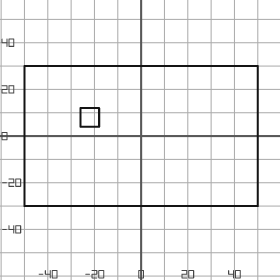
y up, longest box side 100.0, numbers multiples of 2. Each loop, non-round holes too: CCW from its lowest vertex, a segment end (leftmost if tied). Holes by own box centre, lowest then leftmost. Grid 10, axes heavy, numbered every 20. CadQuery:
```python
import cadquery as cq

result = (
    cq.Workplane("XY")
    .moveTo(-50.0, -30.0)
    .lineTo(50.0, -30.0)
    .lineTo(50.0, 30.0)
    .lineTo(-50.0, 30.0)
    .close()
    .moveTo(-26.0, 4.0)
    .lineTo(-18.0, 4.0)
    .lineTo(-18.0, 12.0)
    .lineTo(-26.0, 12.0)
    .close()
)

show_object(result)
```